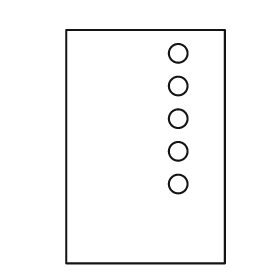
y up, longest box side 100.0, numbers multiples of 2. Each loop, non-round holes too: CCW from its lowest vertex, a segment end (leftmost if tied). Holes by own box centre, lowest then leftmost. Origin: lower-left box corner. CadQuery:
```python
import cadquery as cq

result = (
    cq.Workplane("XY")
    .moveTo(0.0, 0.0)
    .lineTo(68.0, 0.0)
    .lineTo(68.0, 100.0)
    .lineTo(0.0, 100.0)
    .close()
    .moveTo(48.0, 34.0)
    .circle(4.0)
    .moveTo(48.0, 48.0)
    .circle(4.0)
    .moveTo(48.0, 62.0)
    .circle(4.0)
    .moveTo(48.0, 76.0)
    .circle(4.0)
    .moveTo(48.0, 90.0)
    .circle(4.0)
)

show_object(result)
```